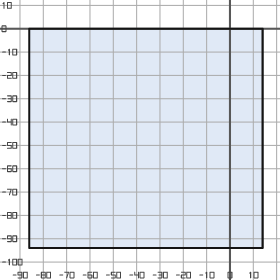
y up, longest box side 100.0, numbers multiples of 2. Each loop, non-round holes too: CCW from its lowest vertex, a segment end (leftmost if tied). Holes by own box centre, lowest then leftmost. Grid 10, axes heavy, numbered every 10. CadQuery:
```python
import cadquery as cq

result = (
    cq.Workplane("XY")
    .moveTo(-86.0, -94.0)
    .lineTo(14.0, -94.0)
    .lineTo(14.0, 0.0)
    .lineTo(-86.0, 0.0)
    .close()
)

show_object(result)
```